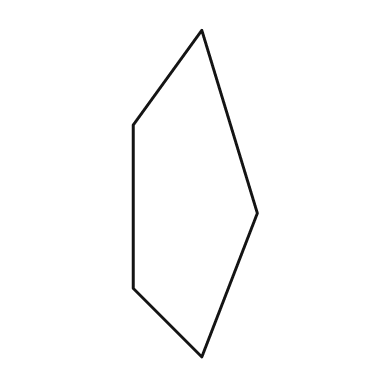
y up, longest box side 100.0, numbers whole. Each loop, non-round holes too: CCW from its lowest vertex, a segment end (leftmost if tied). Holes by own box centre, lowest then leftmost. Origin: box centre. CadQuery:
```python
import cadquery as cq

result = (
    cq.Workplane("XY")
    .moveTo(2.0, -50.0)
    .lineTo(19.0, -6.0)
    .lineTo(2.0, 50.0)
    .lineTo(-19.0, 21.0)
    .lineTo(-19.0, -29.0)
    .close()
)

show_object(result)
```